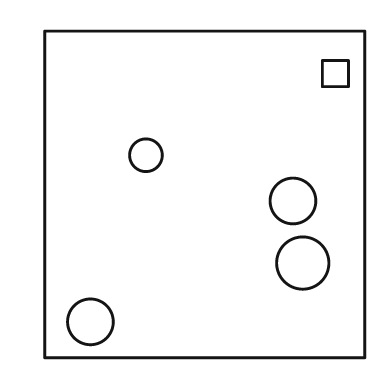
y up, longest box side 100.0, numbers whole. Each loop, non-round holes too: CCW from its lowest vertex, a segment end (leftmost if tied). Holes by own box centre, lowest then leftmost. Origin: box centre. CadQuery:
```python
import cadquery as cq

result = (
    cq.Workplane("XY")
    .moveTo(-49.0, -50.0)
    .lineTo(49.0, -50.0)
    .lineTo(49.0, 50.0)
    .lineTo(-49.0, 50.0)
    .close()
    .moveTo(-35.0, -39.0)
    .circle(7.0)
    .moveTo(30.0, -21.0)
    .circle(8.0)
    .moveTo(27.0, -2.0)
    .circle(7.0)
    .moveTo(-18.0, 12.0)
    .circle(5.0)
    .moveTo(36.0, 33.0)
    .lineTo(44.0, 33.0)
    .lineTo(44.0, 41.0)
    .lineTo(36.0, 41.0)
    .close()
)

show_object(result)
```